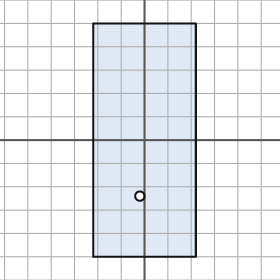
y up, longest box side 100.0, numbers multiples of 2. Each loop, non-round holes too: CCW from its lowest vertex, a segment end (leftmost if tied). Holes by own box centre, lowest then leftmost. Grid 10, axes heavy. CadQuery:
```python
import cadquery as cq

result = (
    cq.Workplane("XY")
    .moveTo(-22.0, -50.0)
    .lineTo(22.0, -50.0)
    .lineTo(22.0, 50.0)
    .lineTo(-22.0, 50.0)
    .close()
    .moveTo(-2.0, -24.0)
    .circle(2.0)
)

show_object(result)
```